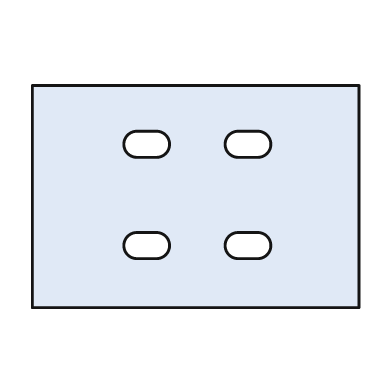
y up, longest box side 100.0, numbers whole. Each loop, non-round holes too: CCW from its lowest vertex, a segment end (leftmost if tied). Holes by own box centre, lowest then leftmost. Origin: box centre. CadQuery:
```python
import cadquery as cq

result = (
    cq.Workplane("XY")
    .moveTo(-50.0, -34.0)
    .lineTo(50.0, -34.0)
    .lineTo(50.0, 34.0)
    .lineTo(-50.0, 34.0)
    .close()
    .moveTo(-18.0, -19.0)
    .lineTo(-12.0, -19.0)
    .threePointArc((-8.0, -15.0), (-12.0, -11.0))
    .lineTo(-18.0, -11.0)
    .threePointArc((-22.0, -15.0), (-18.0, -19.0))
    .close()
    .moveTo(13.0, -19.0)
    .lineTo(19.0, -19.0)
    .threePointArc((23.0, -15.0), (19.0, -11.0))
    .lineTo(13.0, -11.0)
    .threePointArc((9.0, -15.0), (13.0, -19.0))
    .close()
    .moveTo(-18.0, 12.0)
    .lineTo(-12.0, 12.0)
    .threePointArc((-8.0, 16.0), (-12.0, 20.0))
    .lineTo(-18.0, 20.0)
    .threePointArc((-22.0, 16.0), (-18.0, 12.0))
    .close()
    .moveTo(13.0, 12.0)
    .lineTo(19.0, 12.0)
    .threePointArc((23.0, 16.0), (19.0, 20.0))
    .lineTo(13.0, 20.0)
    .threePointArc((9.0, 16.0), (13.0, 12.0))
    .close()
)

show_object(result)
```